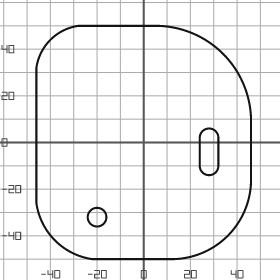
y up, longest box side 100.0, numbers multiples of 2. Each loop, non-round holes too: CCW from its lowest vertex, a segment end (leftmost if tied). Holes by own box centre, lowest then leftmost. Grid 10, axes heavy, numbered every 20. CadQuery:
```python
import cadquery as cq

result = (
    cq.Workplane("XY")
    .moveTo(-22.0, -50.0)
    .lineTo(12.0, -50.0)
    .threePointArc((36.0, -40.0), (46.0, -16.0))
    .lineTo(46.0, 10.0)
    .threePointArc((34.0, 38.0), (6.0, 50.0))
    .lineTo(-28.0, 50.0)
    .threePointArc((-40.0, 44.0), (-46.0, 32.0))
    .lineTo(-46.0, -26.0)
    .threePointArc((-38.0, -42.0), (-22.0, -50.0))
    .close()
    .moveTo(-20.0, -32.0)
    .circle(4.0)
    .moveTo(24.0, -10.0)
    .threePointArc((28.0, -14.0), (32.0, -10.0))
    .lineTo(32.0, 2.0)
    .threePointArc((28.0, 6.0), (24.0, 2.0))
    .close()
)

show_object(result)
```